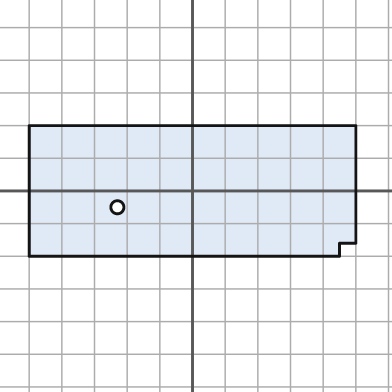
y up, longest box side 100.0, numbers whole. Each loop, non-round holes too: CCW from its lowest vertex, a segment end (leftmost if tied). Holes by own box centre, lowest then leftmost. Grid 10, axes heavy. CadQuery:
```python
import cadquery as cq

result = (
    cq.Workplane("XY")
    .moveTo(-50.0, -20.0)
    .lineTo(45.0, -20.0)
    .lineTo(45.0, -16.0)
    .lineTo(50.0, -16.0)
    .lineTo(50.0, 20.0)
    .lineTo(-50.0, 20.0)
    .close()
    .moveTo(-23.0, -5.0)
    .circle(2.0)
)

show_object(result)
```